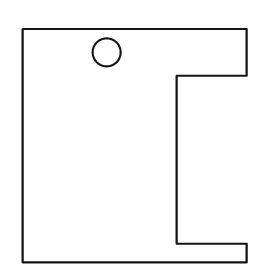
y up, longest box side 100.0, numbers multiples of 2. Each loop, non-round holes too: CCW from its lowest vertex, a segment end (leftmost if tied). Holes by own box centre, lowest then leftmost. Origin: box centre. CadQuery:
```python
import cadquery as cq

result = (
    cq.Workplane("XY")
    .moveTo(-48.0, -50.0)
    .lineTo(48.0, -50.0)
    .lineTo(48.0, -42.0)
    .lineTo(18.0, -42.0)
    .lineTo(18.0, 30.0)
    .lineTo(48.0, 30.0)
    .lineTo(48.0, 50.0)
    .lineTo(-48.0, 50.0)
    .close()
    .moveTo(-12.0, 40.0)
    .circle(6.0)
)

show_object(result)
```